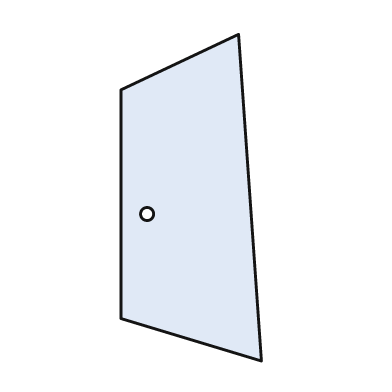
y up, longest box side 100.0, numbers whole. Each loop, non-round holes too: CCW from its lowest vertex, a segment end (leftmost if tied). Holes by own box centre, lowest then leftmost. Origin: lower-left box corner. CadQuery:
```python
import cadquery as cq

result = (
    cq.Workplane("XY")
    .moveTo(43.0, 0.0)
    .lineTo(36.0, 100.0)
    .lineTo(0.0, 83.0)
    .lineTo(0.0, 13.0)
    .close()
    .moveTo(8.0, 45.0)
    .circle(2.0)
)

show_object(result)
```